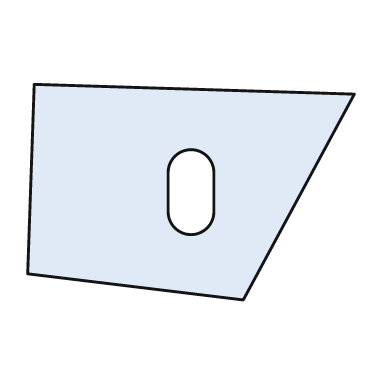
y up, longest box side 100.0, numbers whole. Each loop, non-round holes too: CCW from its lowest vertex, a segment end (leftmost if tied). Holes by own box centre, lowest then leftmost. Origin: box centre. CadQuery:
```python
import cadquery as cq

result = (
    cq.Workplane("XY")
    .moveTo(16.0, -33.0)
    .lineTo(50.0, 30.0)
    .lineTo(-48.0, 33.0)
    .lineTo(-50.0, -25.0)
    .close()
    .moveTo(-7.0, -6.0)
    .threePointArc((0.0, -13.0), (7.0, -6.0))
    .lineTo(7.0, 6.0)
    .threePointArc((0.0, 13.0), (-7.0, 6.0))
    .close()
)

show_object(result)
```